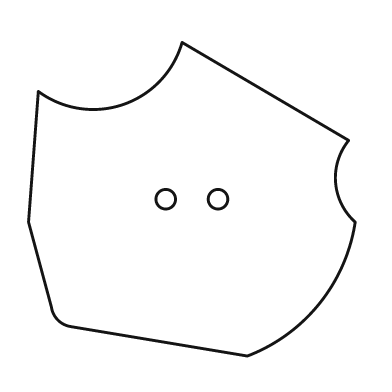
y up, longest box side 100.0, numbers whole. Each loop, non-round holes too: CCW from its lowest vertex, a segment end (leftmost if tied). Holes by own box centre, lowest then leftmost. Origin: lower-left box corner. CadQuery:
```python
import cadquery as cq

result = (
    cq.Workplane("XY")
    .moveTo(67.0, 0.0)
    .threePointArc((89.0, 16.0), (100.0, 41.0))
    .threePointArc((94.0, 53.0), (98.0, 66.0))
    .lineTo(47.0, 96.0)
    .threePointArc((29.0, 77.0), (3.0, 81.0))
    .lineTo(0.0, 41.0)
    .lineTo(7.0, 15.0)
    .threePointArc((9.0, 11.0), (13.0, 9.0))
    .close()
    .moveTo(42.0, 48.0)
    .circle(3.0)
    .moveTo(58.0, 48.0)
    .circle(3.0)
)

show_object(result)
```